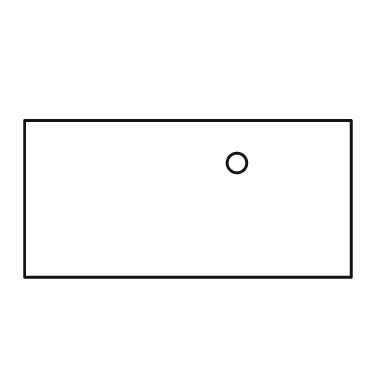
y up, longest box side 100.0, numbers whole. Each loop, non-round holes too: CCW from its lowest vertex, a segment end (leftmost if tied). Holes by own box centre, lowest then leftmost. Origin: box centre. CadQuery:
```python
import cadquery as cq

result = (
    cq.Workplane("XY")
    .moveTo(-50.0, -24.0)
    .lineTo(50.0, -24.0)
    .lineTo(50.0, 24.0)
    .lineTo(-50.0, 24.0)
    .close()
    .moveTo(15.0, 11.0)
    .circle(3.0)
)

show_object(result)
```